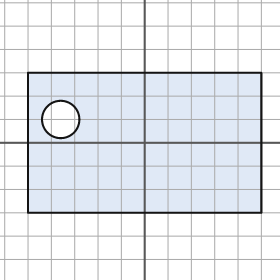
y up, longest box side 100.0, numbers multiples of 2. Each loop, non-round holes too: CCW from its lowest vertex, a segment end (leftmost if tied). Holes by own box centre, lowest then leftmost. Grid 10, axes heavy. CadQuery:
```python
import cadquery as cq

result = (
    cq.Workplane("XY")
    .moveTo(-50.0, -30.0)
    .lineTo(50.0, -30.0)
    .lineTo(50.0, 30.0)
    .lineTo(-50.0, 30.0)
    .close()
    .moveTo(-36.0, 10.0)
    .circle(8.0)
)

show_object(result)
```